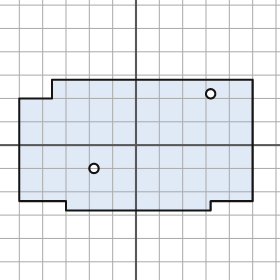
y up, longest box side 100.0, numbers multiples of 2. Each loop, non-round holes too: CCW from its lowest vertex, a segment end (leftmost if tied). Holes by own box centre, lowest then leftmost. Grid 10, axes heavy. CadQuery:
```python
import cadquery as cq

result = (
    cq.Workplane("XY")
    .moveTo(-30.0, -28.0)
    .lineTo(32.0, -28.0)
    .lineTo(32.0, -24.0)
    .lineTo(50.0, -24.0)
    .lineTo(50.0, 28.0)
    .lineTo(-36.0, 28.0)
    .lineTo(-36.0, 20.0)
    .lineTo(-50.0, 20.0)
    .lineTo(-50.0, -24.0)
    .lineTo(-30.0, -24.0)
    .close()
    .moveTo(-18.0, -10.0)
    .circle(2.0)
    .moveTo(32.0, 22.0)
    .circle(2.0)
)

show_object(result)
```